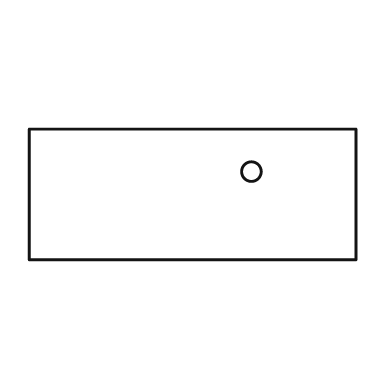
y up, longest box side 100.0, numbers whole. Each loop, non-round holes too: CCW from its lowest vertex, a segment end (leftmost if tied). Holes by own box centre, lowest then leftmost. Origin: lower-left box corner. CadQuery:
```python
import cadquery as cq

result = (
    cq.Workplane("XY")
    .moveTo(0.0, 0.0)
    .lineTo(100.0, 0.0)
    .lineTo(100.0, 40.0)
    .lineTo(0.0, 40.0)
    .close()
    .moveTo(68.0, 27.0)
    .circle(3.0)
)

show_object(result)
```